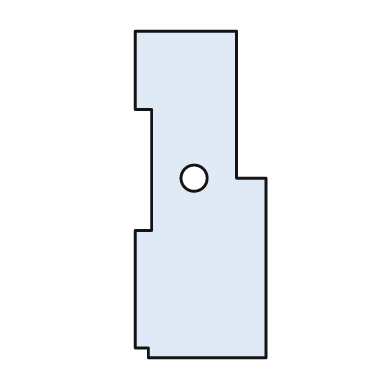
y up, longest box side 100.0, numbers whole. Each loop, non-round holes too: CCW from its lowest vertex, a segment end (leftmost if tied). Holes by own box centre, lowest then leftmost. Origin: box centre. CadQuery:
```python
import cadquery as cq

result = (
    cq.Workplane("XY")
    .moveTo(-16.0, -50.0)
    .lineTo(20.0, -50.0)
    .lineTo(20.0, 5.0)
    .lineTo(11.0, 5.0)
    .lineTo(11.0, 50.0)
    .lineTo(-20.0, 50.0)
    .lineTo(-20.0, 26.0)
    .lineTo(-15.0, 26.0)
    .lineTo(-15.0, -11.0)
    .lineTo(-20.0, -11.0)
    .lineTo(-20.0, -47.0)
    .lineTo(-16.0, -47.0)
    .close()
    .moveTo(-2.0, 5.0)
    .circle(4.0)
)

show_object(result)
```